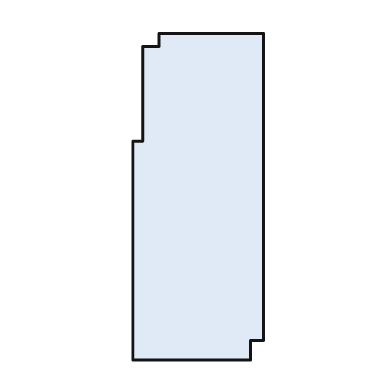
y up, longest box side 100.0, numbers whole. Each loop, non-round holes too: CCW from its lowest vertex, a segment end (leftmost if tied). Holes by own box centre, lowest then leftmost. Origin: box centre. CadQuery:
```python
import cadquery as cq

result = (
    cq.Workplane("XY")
    .moveTo(-20.0, -50.0)
    .lineTo(16.0, -50.0)
    .lineTo(16.0, -44.0)
    .lineTo(20.0, -44.0)
    .lineTo(20.0, 50.0)
    .lineTo(-12.0, 50.0)
    .lineTo(-12.0, 46.0)
    .lineTo(-17.0, 46.0)
    .lineTo(-17.0, 17.0)
    .lineTo(-20.0, 17.0)
    .close()
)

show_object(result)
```